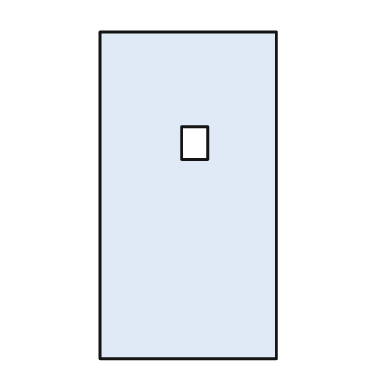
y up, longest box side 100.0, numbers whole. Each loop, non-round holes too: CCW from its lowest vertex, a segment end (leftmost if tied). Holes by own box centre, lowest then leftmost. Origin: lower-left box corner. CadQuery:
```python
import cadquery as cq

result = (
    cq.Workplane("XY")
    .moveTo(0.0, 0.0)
    .lineTo(54.0, 0.0)
    .lineTo(54.0, 100.0)
    .lineTo(0.0, 100.0)
    .close()
    .moveTo(25.0, 61.0)
    .lineTo(33.0, 61.0)
    .lineTo(33.0, 71.0)
    .lineTo(25.0, 71.0)
    .close()
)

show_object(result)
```